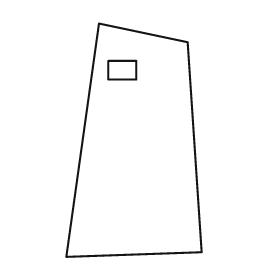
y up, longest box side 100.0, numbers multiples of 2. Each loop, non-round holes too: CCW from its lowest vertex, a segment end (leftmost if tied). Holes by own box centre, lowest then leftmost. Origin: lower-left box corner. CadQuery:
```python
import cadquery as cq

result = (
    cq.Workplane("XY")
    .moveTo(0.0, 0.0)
    .lineTo(58.0, 2.0)
    .lineTo(52.0, 92.0)
    .lineTo(14.0, 100.0)
    .close()
    .moveTo(18.0, 76.0)
    .lineTo(30.0, 76.0)
    .lineTo(30.0, 84.0)
    .lineTo(18.0, 84.0)
    .close()
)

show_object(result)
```